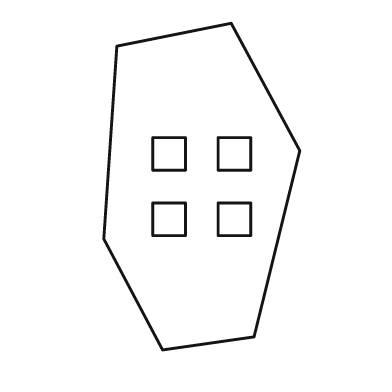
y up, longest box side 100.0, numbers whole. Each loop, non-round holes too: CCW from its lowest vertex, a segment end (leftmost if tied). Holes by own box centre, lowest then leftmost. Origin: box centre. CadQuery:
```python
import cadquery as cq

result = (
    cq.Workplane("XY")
    .moveTo(-12.0, -50.0)
    .lineTo(16.0, -46.0)
    .lineTo(30.0, 11.0)
    .lineTo(9.0, 50.0)
    .lineTo(-26.0, 43.0)
    .lineTo(-30.0, -16.0)
    .close()
    .moveTo(-15.0, -15.0)
    .lineTo(-5.0, -15.0)
    .lineTo(-5.0, -5.0)
    .lineTo(-15.0, -5.0)
    .close()
    .moveTo(5.0, -15.0)
    .lineTo(15.0, -15.0)
    .lineTo(15.0, -5.0)
    .lineTo(5.0, -5.0)
    .close()
    .moveTo(-15.0, 5.0)
    .lineTo(-5.0, 5.0)
    .lineTo(-5.0, 15.0)
    .lineTo(-15.0, 15.0)
    .close()
    .moveTo(5.0, 5.0)
    .lineTo(15.0, 5.0)
    .lineTo(15.0, 15.0)
    .lineTo(5.0, 15.0)
    .close()
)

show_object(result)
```